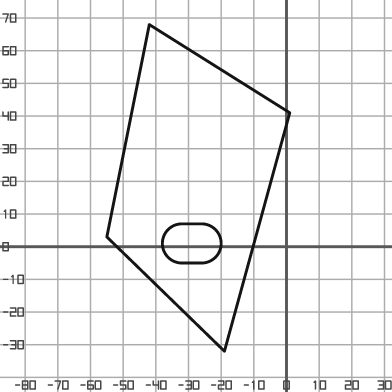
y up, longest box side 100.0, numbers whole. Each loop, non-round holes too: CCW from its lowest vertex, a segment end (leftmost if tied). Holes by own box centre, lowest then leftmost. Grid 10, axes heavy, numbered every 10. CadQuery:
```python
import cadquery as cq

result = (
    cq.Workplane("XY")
    .moveTo(-19.0, -32.0)
    .lineTo(1.0, 41.0)
    .lineTo(-42.0, 68.0)
    .lineTo(-55.0, 3.0)
    .close()
    .moveTo(-32.0, -5.0)
    .lineTo(-26.0, -5.0)
    .threePointArc((-20.0, 1.0), (-26.0, 7.0))
    .lineTo(-32.0, 7.0)
    .threePointArc((-38.0, 1.0), (-32.0, -5.0))
    .close()
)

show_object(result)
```